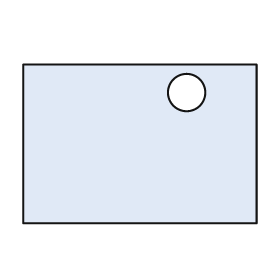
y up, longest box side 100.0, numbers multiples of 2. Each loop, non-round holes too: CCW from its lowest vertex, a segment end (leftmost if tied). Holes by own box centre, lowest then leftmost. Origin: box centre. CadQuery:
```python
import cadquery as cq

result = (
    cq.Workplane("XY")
    .moveTo(-50.0, -34.0)
    .lineTo(50.0, -34.0)
    .lineTo(50.0, 34.0)
    .lineTo(-50.0, 34.0)
    .close()
    .moveTo(20.0, 22.0)
    .circle(8.0)
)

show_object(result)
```